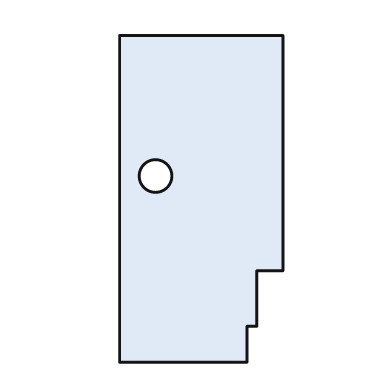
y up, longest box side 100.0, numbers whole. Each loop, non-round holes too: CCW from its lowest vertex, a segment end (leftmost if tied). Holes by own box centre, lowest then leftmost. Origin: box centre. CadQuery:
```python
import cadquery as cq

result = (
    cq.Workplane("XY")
    .moveTo(-25.0, -50.0)
    .lineTo(14.0, -50.0)
    .lineTo(14.0, -39.0)
    .lineTo(17.0, -39.0)
    .lineTo(17.0, -22.0)
    .lineTo(25.0, -22.0)
    .lineTo(25.0, 50.0)
    .lineTo(-25.0, 50.0)
    .close()
    .moveTo(-14.0, 7.0)
    .circle(5.0)
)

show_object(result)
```